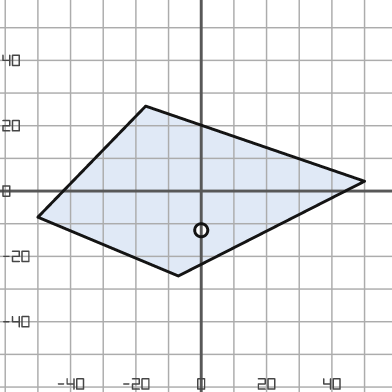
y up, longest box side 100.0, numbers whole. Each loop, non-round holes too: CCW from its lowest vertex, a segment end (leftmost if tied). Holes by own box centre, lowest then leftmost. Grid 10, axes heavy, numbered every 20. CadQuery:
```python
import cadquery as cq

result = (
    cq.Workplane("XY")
    .moveTo(-7.0, -26.0)
    .lineTo(50.0, 3.0)
    .lineTo(-17.0, 26.0)
    .lineTo(-50.0, -8.0)
    .close()
    .moveTo(0.0, -12.0)
    .circle(2.0)
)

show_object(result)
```